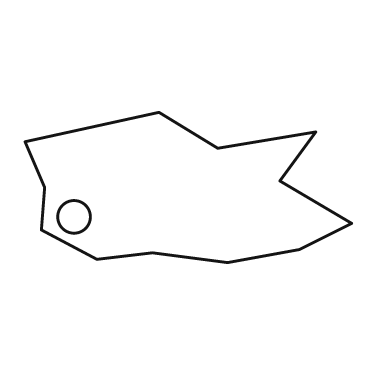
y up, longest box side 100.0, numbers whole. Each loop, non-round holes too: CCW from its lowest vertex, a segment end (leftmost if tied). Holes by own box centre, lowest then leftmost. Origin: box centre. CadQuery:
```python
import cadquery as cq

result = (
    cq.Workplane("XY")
    .moveTo(12.0, -23.0)
    .lineTo(34.0, -19.0)
    .lineTo(50.0, -11.0)
    .lineTo(28.0, 2.0)
    .lineTo(39.0, 17.0)
    .lineTo(9.0, 12.0)
    .lineTo(-9.0, 23.0)
    .lineTo(-50.0, 14.0)
    .lineTo(-44.0, 0.0)
    .lineTo(-45.0, -13.0)
    .lineTo(-28.0, -22.0)
    .lineTo(-11.0, -20.0)
    .close()
    .moveTo(-35.0, -9.0)
    .circle(5.0)
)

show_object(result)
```